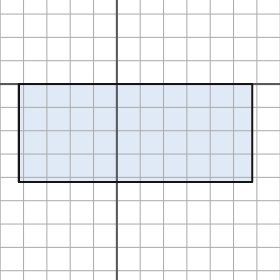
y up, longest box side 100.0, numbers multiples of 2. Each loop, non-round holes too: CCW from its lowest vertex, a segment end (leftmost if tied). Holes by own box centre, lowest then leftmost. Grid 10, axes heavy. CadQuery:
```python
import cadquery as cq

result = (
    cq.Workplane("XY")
    .moveTo(-42.0, -42.0)
    .lineTo(58.0, -42.0)
    .lineTo(58.0, 0.0)
    .lineTo(-42.0, 0.0)
    .close()
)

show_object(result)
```